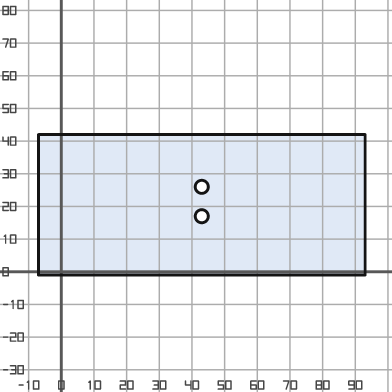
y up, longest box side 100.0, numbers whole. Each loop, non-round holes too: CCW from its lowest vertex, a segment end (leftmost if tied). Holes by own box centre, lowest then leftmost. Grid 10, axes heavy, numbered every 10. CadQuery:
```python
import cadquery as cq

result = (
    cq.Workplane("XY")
    .moveTo(-7.0, -1.0)
    .lineTo(93.0, -1.0)
    .lineTo(93.0, 42.0)
    .lineTo(-7.0, 42.0)
    .close()
    .moveTo(43.0, 17.0)
    .circle(2.0)
    .moveTo(43.0, 26.0)
    .circle(2.0)
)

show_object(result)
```